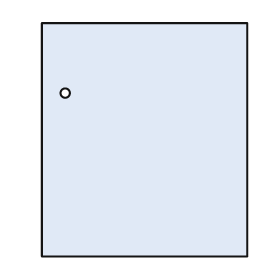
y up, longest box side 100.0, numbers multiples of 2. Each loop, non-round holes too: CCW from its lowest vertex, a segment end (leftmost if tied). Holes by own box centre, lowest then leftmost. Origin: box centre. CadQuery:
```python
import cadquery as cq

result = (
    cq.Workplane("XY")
    .moveTo(-44.0, -50.0)
    .lineTo(44.0, -50.0)
    .lineTo(44.0, 50.0)
    .lineTo(-44.0, 50.0)
    .close()
    .moveTo(-34.0, 20.0)
    .circle(2.0)
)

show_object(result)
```